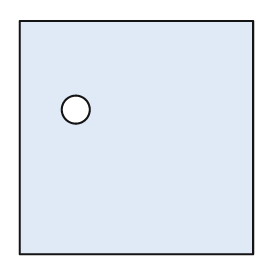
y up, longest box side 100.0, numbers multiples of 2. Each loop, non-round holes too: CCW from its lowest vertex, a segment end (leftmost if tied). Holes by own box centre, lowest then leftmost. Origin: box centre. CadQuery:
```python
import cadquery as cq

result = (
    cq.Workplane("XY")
    .moveTo(-50.0, -50.0)
    .lineTo(50.0, -50.0)
    .lineTo(50.0, 50.0)
    .lineTo(-50.0, 50.0)
    .close()
    .moveTo(-26.0, 12.0)
    .circle(6.0)
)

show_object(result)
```